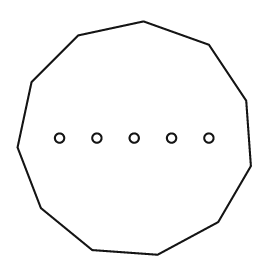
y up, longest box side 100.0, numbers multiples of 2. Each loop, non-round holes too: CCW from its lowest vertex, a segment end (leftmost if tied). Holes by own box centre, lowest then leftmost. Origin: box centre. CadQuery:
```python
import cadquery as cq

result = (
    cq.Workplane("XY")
    .moveTo(10.0, -50.0)
    .lineTo(36.0, -36.0)
    .lineTo(50.0, -12.0)
    .lineTo(48.0, 16.0)
    .lineTo(32.0, 40.0)
    .lineTo(4.0, 50.0)
    .lineTo(-24.0, 44.0)
    .lineTo(-44.0, 24.0)
    .lineTo(-50.0, -4.0)
    .lineTo(-40.0, -30.0)
    .lineTo(-18.0, -48.0)
    .close()
    .moveTo(-32.0, 0.0)
    .circle(2.0)
    .moveTo(-16.0, 0.0)
    .circle(2.0)
    .moveTo(0.0, 0.0)
    .circle(2.0)
    .moveTo(16.0, 0.0)
    .circle(2.0)
    .moveTo(32.0, 0.0)
    .circle(2.0)
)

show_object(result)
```